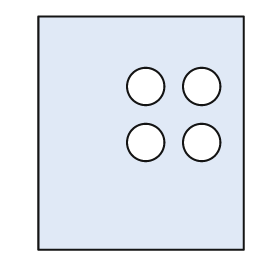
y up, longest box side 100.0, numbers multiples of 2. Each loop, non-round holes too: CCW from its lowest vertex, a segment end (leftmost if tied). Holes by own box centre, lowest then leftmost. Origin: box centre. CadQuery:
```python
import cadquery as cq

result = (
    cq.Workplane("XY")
    .moveTo(-44.0, -50.0)
    .lineTo(44.0, -50.0)
    .lineTo(44.0, 50.0)
    .lineTo(-44.0, 50.0)
    .close()
    .moveTo(2.0, -4.0)
    .circle(8.0)
    .moveTo(26.0, -4.0)
    .circle(8.0)
    .moveTo(2.0, 20.0)
    .circle(8.0)
    .moveTo(26.0, 20.0)
    .circle(8.0)
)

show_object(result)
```